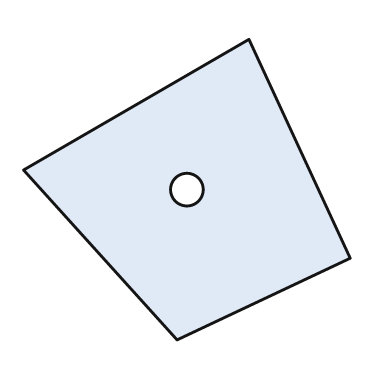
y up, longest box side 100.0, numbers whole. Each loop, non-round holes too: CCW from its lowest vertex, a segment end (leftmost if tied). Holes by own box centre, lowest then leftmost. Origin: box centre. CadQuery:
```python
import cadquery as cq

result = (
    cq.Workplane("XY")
    .moveTo(-3.0, -46.0)
    .lineTo(50.0, -21.0)
    .lineTo(19.0, 46.0)
    .lineTo(-50.0, 6.0)
    .close()
    .moveTo(0.0, 0.0)
    .circle(5.0)
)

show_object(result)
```